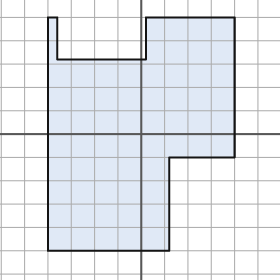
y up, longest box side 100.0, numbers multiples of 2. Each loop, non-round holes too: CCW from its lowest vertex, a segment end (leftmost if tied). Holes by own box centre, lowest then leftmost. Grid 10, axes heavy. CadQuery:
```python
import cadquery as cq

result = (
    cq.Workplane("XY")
    .moveTo(-40.0, -50.0)
    .lineTo(12.0, -50.0)
    .lineTo(12.0, -10.0)
    .lineTo(40.0, -10.0)
    .lineTo(40.0, 50.0)
    .lineTo(2.0, 50.0)
    .lineTo(2.0, 32.0)
    .lineTo(-36.0, 32.0)
    .lineTo(-36.0, 50.0)
    .lineTo(-40.0, 50.0)
    .close()
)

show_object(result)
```